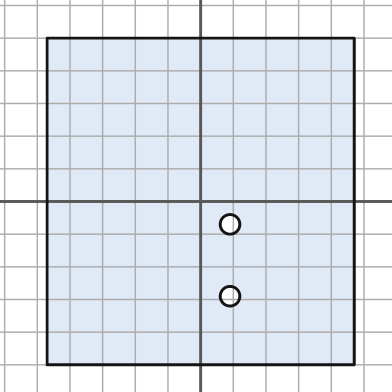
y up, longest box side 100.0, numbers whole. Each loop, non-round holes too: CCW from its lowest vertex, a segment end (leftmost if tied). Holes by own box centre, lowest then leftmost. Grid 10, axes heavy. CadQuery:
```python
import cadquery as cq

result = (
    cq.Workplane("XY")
    .moveTo(-47.0, -50.0)
    .lineTo(47.0, -50.0)
    .lineTo(47.0, 50.0)
    .lineTo(-47.0, 50.0)
    .close()
    .moveTo(9.0, -29.0)
    .circle(3.0)
    .moveTo(9.0, -7.0)
    .circle(3.0)
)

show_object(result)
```